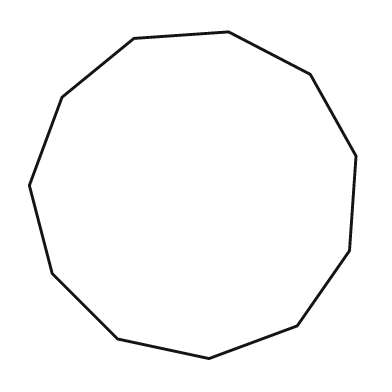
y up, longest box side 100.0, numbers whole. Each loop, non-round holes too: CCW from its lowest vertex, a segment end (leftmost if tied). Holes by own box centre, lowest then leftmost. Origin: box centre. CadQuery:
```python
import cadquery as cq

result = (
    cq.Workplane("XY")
    .moveTo(5.0, -50.0)
    .lineTo(32.0, -40.0)
    .lineTo(48.0, -17.0)
    .lineTo(50.0, 12.0)
    .lineTo(36.0, 37.0)
    .lineTo(11.0, 50.0)
    .lineTo(-18.0, 48.0)
    .lineTo(-40.0, 30.0)
    .lineTo(-50.0, 3.0)
    .lineTo(-43.0, -24.0)
    .lineTo(-23.0, -44.0)
    .close()
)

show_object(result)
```